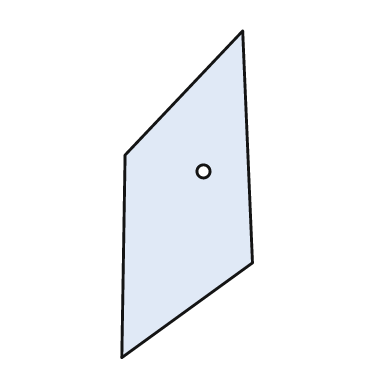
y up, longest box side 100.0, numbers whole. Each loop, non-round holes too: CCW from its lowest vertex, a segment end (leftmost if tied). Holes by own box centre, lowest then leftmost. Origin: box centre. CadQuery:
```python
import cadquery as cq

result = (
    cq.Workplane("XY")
    .moveTo(-20.0, -50.0)
    .lineTo(20.0, -21.0)
    .lineTo(17.0, 50.0)
    .lineTo(-19.0, 12.0)
    .close()
    .moveTo(5.0, 7.0)
    .circle(2.0)
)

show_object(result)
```